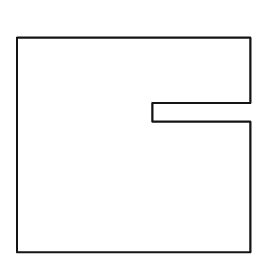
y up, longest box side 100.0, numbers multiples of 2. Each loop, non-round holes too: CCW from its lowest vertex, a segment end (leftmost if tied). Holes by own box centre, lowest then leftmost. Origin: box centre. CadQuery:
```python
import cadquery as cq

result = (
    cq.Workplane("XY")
    .moveTo(-50.0, -46.0)
    .lineTo(50.0, -46.0)
    .lineTo(50.0, 10.0)
    .lineTo(8.0, 10.0)
    .lineTo(8.0, 18.0)
    .lineTo(50.0, 18.0)
    .lineTo(50.0, 46.0)
    .lineTo(-50.0, 46.0)
    .close()
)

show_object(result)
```